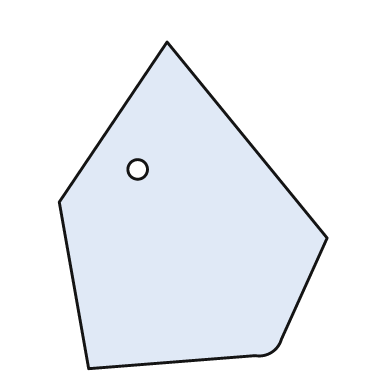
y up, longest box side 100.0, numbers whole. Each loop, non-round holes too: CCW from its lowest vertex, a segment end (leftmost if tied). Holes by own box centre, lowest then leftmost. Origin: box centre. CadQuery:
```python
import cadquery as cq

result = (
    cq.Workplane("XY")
    .moveTo(-32.0, -50.0)
    .lineTo(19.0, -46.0)
    .threePointArc((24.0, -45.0), (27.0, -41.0))
    .lineTo(41.0, -10.0)
    .lineTo(-8.0, 50.0)
    .lineTo(-41.0, 1.0)
    .close()
    .moveTo(-17.0, 11.0)
    .circle(3.0)
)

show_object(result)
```